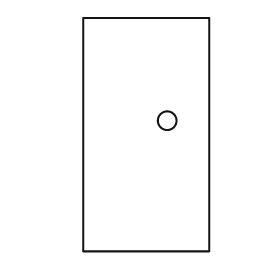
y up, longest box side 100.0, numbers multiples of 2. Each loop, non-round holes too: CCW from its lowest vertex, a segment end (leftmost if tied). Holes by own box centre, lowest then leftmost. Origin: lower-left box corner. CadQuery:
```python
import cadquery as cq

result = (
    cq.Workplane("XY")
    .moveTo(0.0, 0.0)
    .lineTo(54.0, 0.0)
    .lineTo(54.0, 100.0)
    .lineTo(0.0, 100.0)
    .close()
    .moveTo(36.0, 56.0)
    .circle(4.0)
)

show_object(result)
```